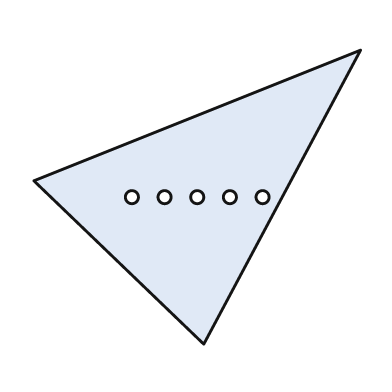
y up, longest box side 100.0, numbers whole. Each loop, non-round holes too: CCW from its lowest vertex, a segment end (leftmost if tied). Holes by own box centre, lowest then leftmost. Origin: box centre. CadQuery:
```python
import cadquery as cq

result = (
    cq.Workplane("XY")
    .moveTo(2.0, -45.0)
    .lineTo(50.0, 45.0)
    .lineTo(-50.0, 5.0)
    .close()
    .moveTo(-20.0, 0.0)
    .circle(2.0)
    .moveTo(-10.0, 0.0)
    .circle(2.0)
    .moveTo(0.0, 0.0)
    .circle(2.0)
    .moveTo(10.0, 0.0)
    .circle(2.0)
    .moveTo(20.0, 0.0)
    .circle(2.0)
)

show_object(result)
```